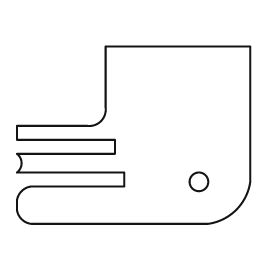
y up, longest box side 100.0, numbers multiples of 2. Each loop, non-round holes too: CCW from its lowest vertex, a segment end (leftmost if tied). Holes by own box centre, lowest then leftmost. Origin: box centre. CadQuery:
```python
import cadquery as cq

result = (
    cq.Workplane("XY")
    .moveTo(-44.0, -38.0)
    .lineTo(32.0, -38.0)
    .threePointArc((44.0, -32.0), (50.0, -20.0))
    .lineTo(50.0, 38.0)
    .lineTo(-12.0, 38.0)
    .lineTo(-12.0, 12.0)
    .threePointArc((-14.0, 6.0), (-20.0, 4.0))
    .lineTo(-50.0, 4.0)
    .lineTo(-50.0, -2.0)
    .lineTo(-8.0, -2.0)
    .lineTo(-8.0, -8.0)
    .lineTo(-50.0, -8.0)
    .threePointArc((-48.0, -12.0), (-50.0, -16.0))
    .lineTo(-4.0, -16.0)
    .lineTo(-4.0, -22.0)
    .lineTo(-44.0, -22.0)
    .threePointArc((-48.0, -24.0), (-50.0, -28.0))
    .lineTo(-50.0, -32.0)
    .threePointArc((-48.0, -36.0), (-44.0, -38.0))
    .close()
    .moveTo(28.0, -20.0)
    .circle(4.0)
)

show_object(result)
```